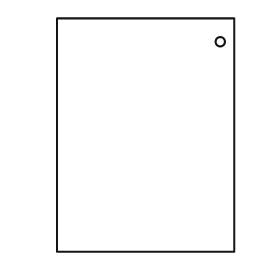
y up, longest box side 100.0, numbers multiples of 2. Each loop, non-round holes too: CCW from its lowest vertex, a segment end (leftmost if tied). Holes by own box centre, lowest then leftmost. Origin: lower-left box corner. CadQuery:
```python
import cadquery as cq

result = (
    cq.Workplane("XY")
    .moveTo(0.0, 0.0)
    .lineTo(76.0, 0.0)
    .lineTo(76.0, 100.0)
    .lineTo(0.0, 100.0)
    .close()
    .moveTo(70.0, 90.0)
    .circle(2.0)
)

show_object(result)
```